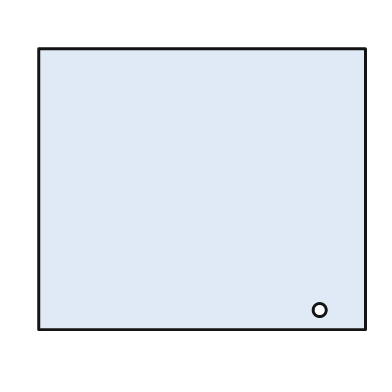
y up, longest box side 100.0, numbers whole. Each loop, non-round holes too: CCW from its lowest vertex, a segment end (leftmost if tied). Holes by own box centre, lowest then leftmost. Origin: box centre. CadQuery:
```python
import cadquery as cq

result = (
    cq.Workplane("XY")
    .moveTo(-50.0, -43.0)
    .lineTo(50.0, -43.0)
    .lineTo(50.0, 43.0)
    .lineTo(-50.0, 43.0)
    .close()
    .moveTo(36.0, -37.0)
    .circle(2.0)
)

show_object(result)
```